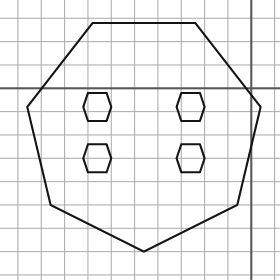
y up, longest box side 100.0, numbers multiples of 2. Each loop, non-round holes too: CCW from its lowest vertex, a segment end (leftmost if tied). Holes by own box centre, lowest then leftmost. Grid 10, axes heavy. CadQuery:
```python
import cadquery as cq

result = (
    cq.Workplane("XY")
    .moveTo(-46.0, -70.0)
    .lineTo(-6.0, -50.0)
    .lineTo(4.0, -8.0)
    .lineTo(-24.0, 28.0)
    .lineTo(-68.0, 28.0)
    .lineTo(-96.0, -8.0)
    .lineTo(-86.0, -50.0)
    .close()
    .moveTo(-70.0, -36.0)
    .lineTo(-62.0, -36.0)
    .lineTo(-60.0, -30.0)
    .lineTo(-62.0, -24.0)
    .lineTo(-70.0, -24.0)
    .lineTo(-72.0, -30.0)
    .close()
    .moveTo(-30.0, -36.0)
    .lineTo(-22.0, -36.0)
    .lineTo(-20.0, -30.0)
    .lineTo(-22.0, -24.0)
    .lineTo(-30.0, -24.0)
    .lineTo(-32.0, -30.0)
    .close()
    .moveTo(-70.0, -14.0)
    .lineTo(-62.0, -14.0)
    .lineTo(-60.0, -8.0)
    .lineTo(-62.0, -2.0)
    .lineTo(-70.0, -2.0)
    .lineTo(-72.0, -8.0)
    .close()
    .moveTo(-30.0, -14.0)
    .lineTo(-22.0, -14.0)
    .lineTo(-20.0, -8.0)
    .lineTo(-22.0, -2.0)
    .lineTo(-30.0, -2.0)
    .lineTo(-32.0, -8.0)
    .close()
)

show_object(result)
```